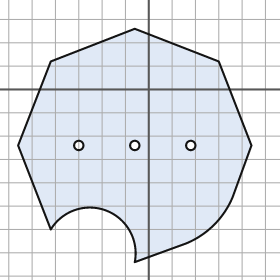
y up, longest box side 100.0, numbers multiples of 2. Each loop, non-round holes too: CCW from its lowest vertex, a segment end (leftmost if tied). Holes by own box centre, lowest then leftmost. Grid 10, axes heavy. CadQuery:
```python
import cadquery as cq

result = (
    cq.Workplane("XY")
    .moveTo(-6.0, -74.0)
    .lineTo(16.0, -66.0)
    .threePointArc((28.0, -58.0), (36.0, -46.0))
    .lineTo(44.0, -24.0)
    .lineTo(30.0, 12.0)
    .lineTo(-6.0, 26.0)
    .lineTo(-42.0, 12.0)
    .lineTo(-56.0, -24.0)
    .lineTo(-42.0, -60.0)
    .threePointArc((-18.0, -52.0), (-6.0, -74.0))
    .close()
    .moveTo(-30.0, -24.0)
    .circle(2.0)
    .moveTo(-6.0, -24.0)
    .circle(2.0)
    .moveTo(18.0, -24.0)
    .circle(2.0)
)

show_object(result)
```